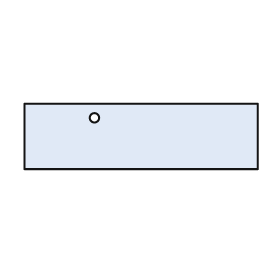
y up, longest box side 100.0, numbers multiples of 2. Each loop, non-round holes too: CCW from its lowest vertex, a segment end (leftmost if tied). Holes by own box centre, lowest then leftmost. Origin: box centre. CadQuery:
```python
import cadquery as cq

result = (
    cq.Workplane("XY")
    .moveTo(-50.0, -14.0)
    .lineTo(50.0, -14.0)
    .lineTo(50.0, 14.0)
    .lineTo(-50.0, 14.0)
    .close()
    .moveTo(-20.0, 8.0)
    .circle(2.0)
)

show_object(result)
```